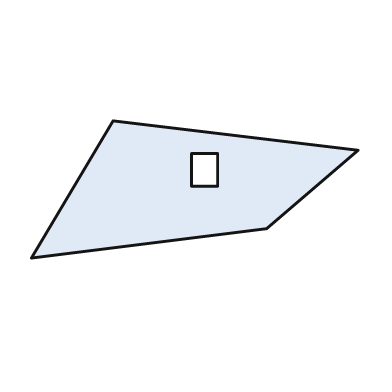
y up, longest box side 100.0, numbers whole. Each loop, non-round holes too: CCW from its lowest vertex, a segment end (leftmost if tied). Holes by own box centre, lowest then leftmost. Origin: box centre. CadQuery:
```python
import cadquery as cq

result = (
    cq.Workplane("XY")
    .moveTo(-50.0, -21.0)
    .lineTo(22.0, -12.0)
    .lineTo(50.0, 12.0)
    .lineTo(-25.0, 21.0)
    .close()
    .moveTo(-1.0, 1.0)
    .lineTo(7.0, 1.0)
    .lineTo(7.0, 11.0)
    .lineTo(-1.0, 11.0)
    .close()
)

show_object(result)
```